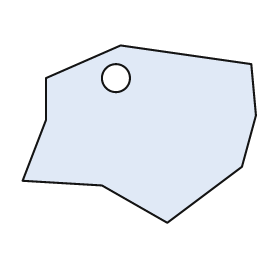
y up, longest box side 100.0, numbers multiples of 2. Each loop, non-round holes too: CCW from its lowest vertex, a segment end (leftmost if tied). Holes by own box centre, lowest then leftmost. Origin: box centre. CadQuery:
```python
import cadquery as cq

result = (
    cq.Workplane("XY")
    .moveTo(12.0, -38.0)
    .lineTo(44.0, -14.0)
    .lineTo(50.0, 8.0)
    .lineTo(48.0, 30.0)
    .lineTo(-8.0, 38.0)
    .lineTo(-40.0, 24.0)
    .lineTo(-40.0, 6.0)
    .lineTo(-50.0, -20.0)
    .lineTo(-16.0, -22.0)
    .close()
    .moveTo(-10.0, 24.0)
    .circle(6.0)
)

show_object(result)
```